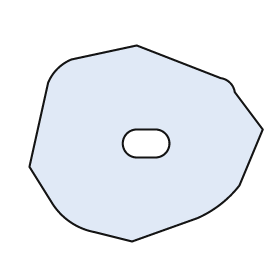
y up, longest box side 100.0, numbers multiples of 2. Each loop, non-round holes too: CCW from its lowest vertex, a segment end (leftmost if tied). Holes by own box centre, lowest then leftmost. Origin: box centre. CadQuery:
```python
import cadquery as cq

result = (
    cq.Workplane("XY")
    .moveTo(-6.0, -42.0)
    .lineTo(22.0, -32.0)
    .threePointArc((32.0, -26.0), (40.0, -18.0))
    .lineTo(50.0, 6.0)
    .lineTo(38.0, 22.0)
    .threePointArc((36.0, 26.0), (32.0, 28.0))
    .lineTo(-4.0, 42.0)
    .lineTo(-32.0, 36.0)
    .threePointArc((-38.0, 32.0), (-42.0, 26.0))
    .lineTo(-50.0, -10.0)
    .lineTo(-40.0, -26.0)
    .threePointArc((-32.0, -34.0), (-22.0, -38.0))
    .close()
    .moveTo(-4.0, -6.0)
    .lineTo(4.0, -6.0)
    .threePointArc((10.0, 0.0), (4.0, 6.0))
    .lineTo(-4.0, 6.0)
    .threePointArc((-10.0, 0.0), (-4.0, -6.0))
    .close()
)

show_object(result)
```